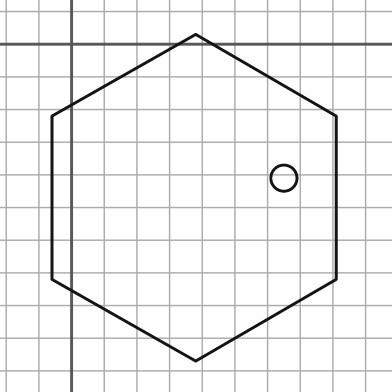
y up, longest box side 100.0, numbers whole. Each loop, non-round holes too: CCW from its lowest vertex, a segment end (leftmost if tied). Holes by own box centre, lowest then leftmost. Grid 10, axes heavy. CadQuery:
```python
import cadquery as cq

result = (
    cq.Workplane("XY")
    .moveTo(38.0, -97.0)
    .lineTo(81.0, -72.0)
    .lineTo(81.0, -22.0)
    .lineTo(38.0, 3.0)
    .lineTo(-6.0, -22.0)
    .lineTo(-6.0, -72.0)
    .close()
    .moveTo(65.0, -41.0)
    .circle(4.0)
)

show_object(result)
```